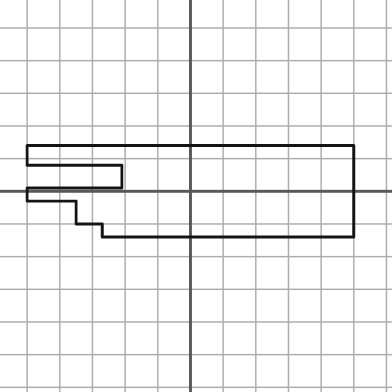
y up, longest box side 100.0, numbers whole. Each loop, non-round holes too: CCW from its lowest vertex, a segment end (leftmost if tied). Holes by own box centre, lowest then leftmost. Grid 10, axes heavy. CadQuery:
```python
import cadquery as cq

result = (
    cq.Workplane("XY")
    .moveTo(-27.0, -14.0)
    .lineTo(50.0, -14.0)
    .lineTo(50.0, 14.0)
    .lineTo(-50.0, 14.0)
    .lineTo(-50.0, 8.0)
    .lineTo(-21.0, 8.0)
    .lineTo(-21.0, 1.0)
    .lineTo(-50.0, 1.0)
    .lineTo(-50.0, -3.0)
    .lineTo(-35.0, -3.0)
    .lineTo(-35.0, -10.0)
    .lineTo(-27.0, -10.0)
    .close()
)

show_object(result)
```